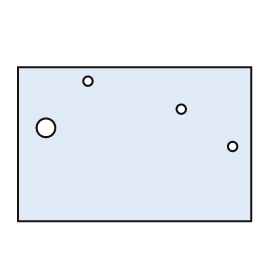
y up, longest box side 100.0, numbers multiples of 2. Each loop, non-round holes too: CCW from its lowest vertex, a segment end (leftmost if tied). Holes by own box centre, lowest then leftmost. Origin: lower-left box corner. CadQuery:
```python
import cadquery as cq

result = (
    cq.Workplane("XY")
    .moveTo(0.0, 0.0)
    .lineTo(100.0, 0.0)
    .lineTo(100.0, 66.0)
    .lineTo(0.0, 66.0)
    .close()
    .moveTo(92.0, 32.0)
    .circle(2.0)
    .moveTo(12.0, 40.0)
    .circle(4.0)
    .moveTo(70.0, 48.0)
    .circle(2.0)
    .moveTo(30.0, 60.0)
    .circle(2.0)
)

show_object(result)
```